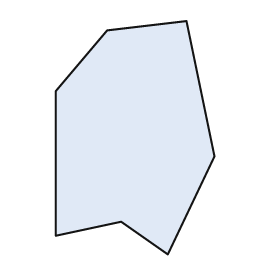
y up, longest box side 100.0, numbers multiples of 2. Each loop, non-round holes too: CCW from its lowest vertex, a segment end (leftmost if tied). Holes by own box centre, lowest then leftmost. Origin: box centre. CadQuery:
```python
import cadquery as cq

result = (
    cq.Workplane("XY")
    .moveTo(14.0, -50.0)
    .lineTo(34.0, -8.0)
    .lineTo(22.0, 50.0)
    .lineTo(-12.0, 46.0)
    .lineTo(-34.0, 20.0)
    .lineTo(-34.0, -42.0)
    .lineTo(-6.0, -36.0)
    .close()
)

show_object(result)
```